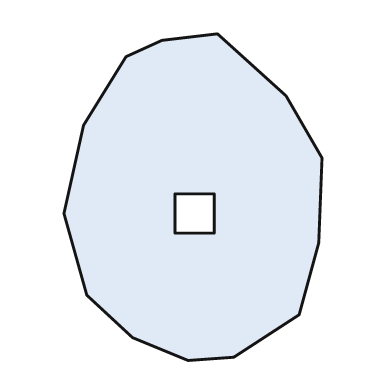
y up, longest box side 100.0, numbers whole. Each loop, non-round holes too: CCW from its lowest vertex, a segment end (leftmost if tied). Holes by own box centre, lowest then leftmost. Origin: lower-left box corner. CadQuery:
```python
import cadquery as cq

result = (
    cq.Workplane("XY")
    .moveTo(38.0, 0.0)
    .lineTo(52.0, 1.0)
    .lineTo(72.0, 14.0)
    .lineTo(78.0, 36.0)
    .lineTo(79.0, 62.0)
    .lineTo(68.0, 81.0)
    .lineTo(47.0, 100.0)
    .lineTo(30.0, 98.0)
    .lineTo(19.0, 93.0)
    .lineTo(6.0, 72.0)
    .lineTo(0.0, 45.0)
    .lineTo(7.0, 20.0)
    .lineTo(21.0, 7.0)
    .close()
    .moveTo(34.0, 39.0)
    .lineTo(46.0, 39.0)
    .lineTo(46.0, 51.0)
    .lineTo(34.0, 51.0)
    .close()
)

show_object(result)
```